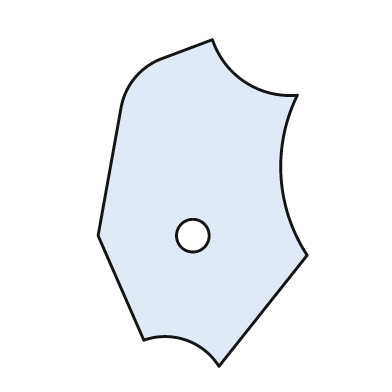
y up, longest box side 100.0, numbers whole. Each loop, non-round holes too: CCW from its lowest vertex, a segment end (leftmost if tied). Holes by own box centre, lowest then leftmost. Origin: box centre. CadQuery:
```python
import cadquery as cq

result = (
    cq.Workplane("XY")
    .moveTo(5.0, -50.0)
    .lineTo(32.0, -16.0)
    .threePointArc((24.0, 8.0), (29.0, 33.0))
    .threePointArc((13.0, 37.0), (3.0, 50.0))
    .lineTo(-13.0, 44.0)
    .threePointArc((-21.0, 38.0), (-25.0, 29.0))
    .lineTo(-32.0, -10.0)
    .lineTo(-18.0, -42.0)
    .threePointArc((-5.0, -42.0), (5.0, -50.0))
    .close()
    .moveTo(-3.0, -10.0)
    .circle(5.0)
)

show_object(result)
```